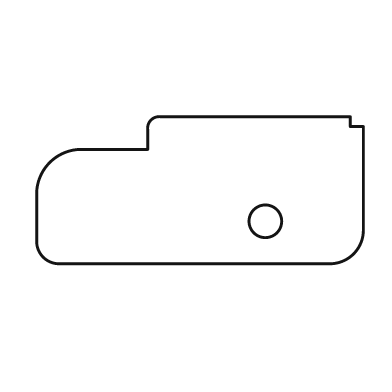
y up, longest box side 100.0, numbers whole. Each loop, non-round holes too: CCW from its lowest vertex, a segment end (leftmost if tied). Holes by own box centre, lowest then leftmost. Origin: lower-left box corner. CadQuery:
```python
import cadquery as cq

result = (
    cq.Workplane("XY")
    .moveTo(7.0, 0.0)
    .lineTo(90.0, 0.0)
    .threePointArc((97.0, 3.0), (100.0, 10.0))
    .lineTo(100.0, 42.0)
    .lineTo(96.0, 42.0)
    .lineTo(96.0, 45.0)
    .lineTo(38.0, 45.0)
    .threePointArc((35.0, 44.0), (34.0, 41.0))
    .lineTo(34.0, 35.0)
    .lineTo(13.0, 35.0)
    .threePointArc((4.0, 31.0), (0.0, 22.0))
    .lineTo(0.0, 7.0)
    .threePointArc((2.0, 2.0), (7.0, 0.0))
    .close()
    .moveTo(70.0, 13.0)
    .circle(5.0)
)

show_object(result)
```